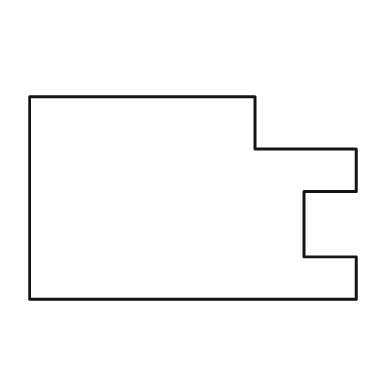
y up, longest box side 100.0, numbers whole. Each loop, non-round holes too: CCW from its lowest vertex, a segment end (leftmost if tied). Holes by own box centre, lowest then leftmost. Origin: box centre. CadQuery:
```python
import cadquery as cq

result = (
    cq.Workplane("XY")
    .moveTo(-50.0, -31.0)
    .lineTo(50.0, -31.0)
    .lineTo(50.0, -18.0)
    .lineTo(34.0, -18.0)
    .lineTo(34.0, 2.0)
    .lineTo(50.0, 2.0)
    .lineTo(50.0, 15.0)
    .lineTo(19.0, 15.0)
    .lineTo(19.0, 31.0)
    .lineTo(-50.0, 31.0)
    .close()
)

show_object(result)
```